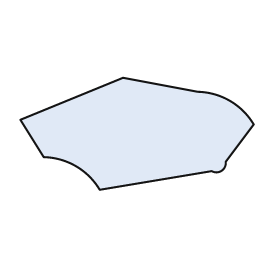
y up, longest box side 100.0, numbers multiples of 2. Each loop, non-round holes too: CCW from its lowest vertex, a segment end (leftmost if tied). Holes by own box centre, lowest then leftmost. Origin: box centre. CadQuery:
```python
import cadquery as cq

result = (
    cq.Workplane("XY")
    .moveTo(-16.0, -24.0)
    .lineTo(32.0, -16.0)
    .threePointArc((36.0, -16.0), (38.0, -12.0))
    .lineTo(50.0, 4.0)
    .threePointArc((40.0, 14.0), (26.0, 18.0))
    .lineTo(-6.0, 24.0)
    .lineTo(-50.0, 6.0)
    .lineTo(-40.0, -10.0)
    .threePointArc((-26.0, -14.0), (-16.0, -24.0))
    .close()
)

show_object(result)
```